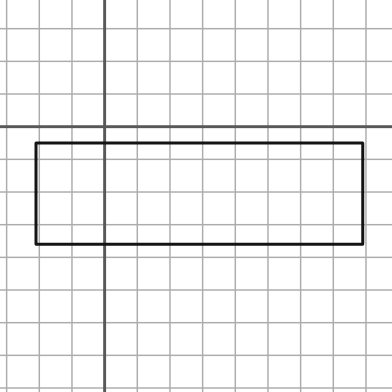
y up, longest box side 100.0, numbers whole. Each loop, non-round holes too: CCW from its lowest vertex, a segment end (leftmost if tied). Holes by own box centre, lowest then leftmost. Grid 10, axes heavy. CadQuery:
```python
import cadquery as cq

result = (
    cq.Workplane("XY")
    .moveTo(-21.0, -36.0)
    .lineTo(79.0, -36.0)
    .lineTo(79.0, -5.0)
    .lineTo(-21.0, -5.0)
    .close()
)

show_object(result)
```